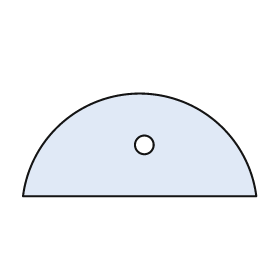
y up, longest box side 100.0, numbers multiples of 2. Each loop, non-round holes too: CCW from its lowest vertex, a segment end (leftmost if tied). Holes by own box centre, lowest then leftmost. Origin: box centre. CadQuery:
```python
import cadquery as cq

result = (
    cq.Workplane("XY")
    .moveTo(-50.0, -22.0)
    .lineTo(50.0, -22.0)
    .threePointArc((0.0, 22.0), (-50.0, -22.0))
    .close()
    .moveTo(2.0, 0.0)
    .circle(4.0)
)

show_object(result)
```